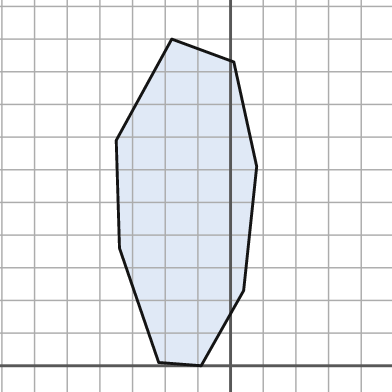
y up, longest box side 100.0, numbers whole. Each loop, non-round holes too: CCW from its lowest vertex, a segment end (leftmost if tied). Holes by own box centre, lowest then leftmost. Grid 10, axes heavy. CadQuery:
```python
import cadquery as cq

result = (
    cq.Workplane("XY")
    .moveTo(-9.0, 0.0)
    .lineTo(4.0, 23.0)
    .lineTo(8.0, 61.0)
    .lineTo(1.0, 93.0)
    .lineTo(-18.0, 100.0)
    .lineTo(-35.0, 69.0)
    .lineTo(-34.0, 36.0)
    .lineTo(-22.0, 1.0)
    .close()
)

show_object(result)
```